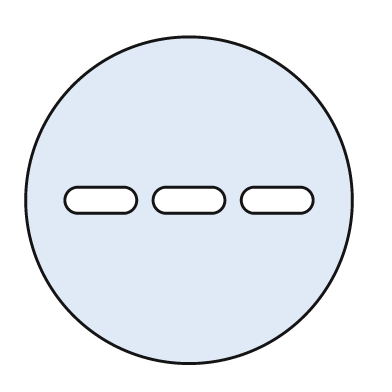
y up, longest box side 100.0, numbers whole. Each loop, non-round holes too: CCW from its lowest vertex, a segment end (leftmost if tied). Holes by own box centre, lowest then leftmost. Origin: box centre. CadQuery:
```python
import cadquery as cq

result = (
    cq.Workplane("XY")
    .moveTo(0.0, 0.0)
    .circle(50.0)
    .moveTo(-34.0, -4.0)
    .lineTo(-20.0, -4.0)
    .threePointArc((-16.0, 0.0), (-20.0, 4.0))
    .lineTo(-34.0, 4.0)
    .threePointArc((-38.0, 0.0), (-34.0, -4.0))
    .close()
    .moveTo(-7.0, -4.0)
    .lineTo(7.0, -4.0)
    .threePointArc((11.0, 0.0), (7.0, 4.0))
    .lineTo(-7.0, 4.0)
    .threePointArc((-11.0, 0.0), (-7.0, -4.0))
    .close()
    .moveTo(20.0, -4.0)
    .lineTo(34.0, -4.0)
    .threePointArc((38.0, 0.0), (34.0, 4.0))
    .lineTo(20.0, 4.0)
    .threePointArc((16.0, 0.0), (20.0, -4.0))
    .close()
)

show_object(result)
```